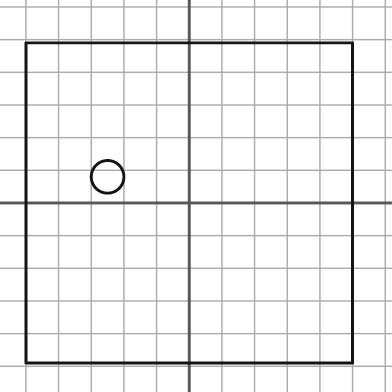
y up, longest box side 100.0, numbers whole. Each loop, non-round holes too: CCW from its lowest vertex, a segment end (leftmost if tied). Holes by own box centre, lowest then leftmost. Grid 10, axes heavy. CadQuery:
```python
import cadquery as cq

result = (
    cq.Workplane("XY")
    .moveTo(-50.0, -49.0)
    .lineTo(50.0, -49.0)
    .lineTo(50.0, 49.0)
    .lineTo(-50.0, 49.0)
    .close()
    .moveTo(-25.0, 8.0)
    .circle(5.0)
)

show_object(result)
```